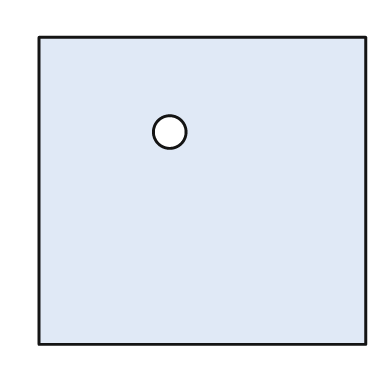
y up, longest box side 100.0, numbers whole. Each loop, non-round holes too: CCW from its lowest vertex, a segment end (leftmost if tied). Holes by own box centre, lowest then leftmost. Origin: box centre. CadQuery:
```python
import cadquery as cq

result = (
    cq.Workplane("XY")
    .moveTo(-50.0, -47.0)
    .lineTo(50.0, -47.0)
    .lineTo(50.0, 47.0)
    .lineTo(-50.0, 47.0)
    .close()
    .moveTo(-10.0, 18.0)
    .circle(5.0)
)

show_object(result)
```